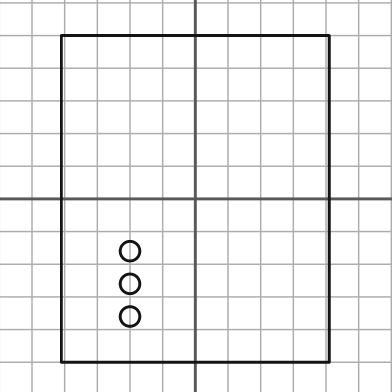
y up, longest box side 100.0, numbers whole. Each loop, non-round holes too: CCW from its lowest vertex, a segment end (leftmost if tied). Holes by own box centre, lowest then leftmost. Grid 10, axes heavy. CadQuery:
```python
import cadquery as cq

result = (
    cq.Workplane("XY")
    .moveTo(-41.0, -50.0)
    .lineTo(41.0, -50.0)
    .lineTo(41.0, 50.0)
    .lineTo(-41.0, 50.0)
    .close()
    .moveTo(-20.0, -36.0)
    .circle(3.0)
    .moveTo(-20.0, -26.0)
    .circle(3.0)
    .moveTo(-20.0, -16.0)
    .circle(3.0)
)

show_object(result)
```